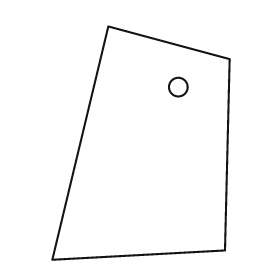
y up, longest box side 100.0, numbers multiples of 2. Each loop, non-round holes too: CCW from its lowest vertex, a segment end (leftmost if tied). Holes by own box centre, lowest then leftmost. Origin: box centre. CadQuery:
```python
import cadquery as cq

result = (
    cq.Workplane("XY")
    .moveTo(-38.0, -50.0)
    .lineTo(36.0, -46.0)
    .lineTo(38.0, 36.0)
    .lineTo(-14.0, 50.0)
    .close()
    .moveTo(16.0, 24.0)
    .circle(4.0)
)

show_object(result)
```